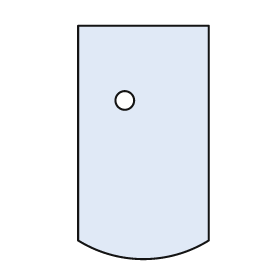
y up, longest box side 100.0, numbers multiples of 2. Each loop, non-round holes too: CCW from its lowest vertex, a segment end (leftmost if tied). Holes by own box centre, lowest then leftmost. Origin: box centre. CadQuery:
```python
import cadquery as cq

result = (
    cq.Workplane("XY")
    .moveTo(-28.0, -42.0)
    .threePointArc((0.0, -50.0), (28.0, -42.0))
    .lineTo(28.0, 50.0)
    .lineTo(-28.0, 50.0)
    .close()
    .moveTo(-8.0, 18.0)
    .circle(4.0)
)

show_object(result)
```